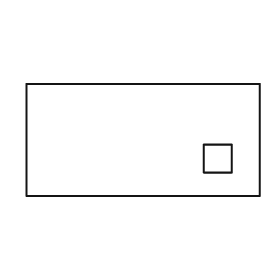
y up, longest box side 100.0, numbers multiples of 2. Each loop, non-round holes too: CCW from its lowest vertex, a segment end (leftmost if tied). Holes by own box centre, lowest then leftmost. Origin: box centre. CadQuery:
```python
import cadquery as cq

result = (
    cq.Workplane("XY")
    .moveTo(-50.0, -24.0)
    .lineTo(50.0, -24.0)
    .lineTo(50.0, 24.0)
    .lineTo(-50.0, 24.0)
    .close()
    .moveTo(26.0, -14.0)
    .lineTo(38.0, -14.0)
    .lineTo(38.0, -2.0)
    .lineTo(26.0, -2.0)
    .close()
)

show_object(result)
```